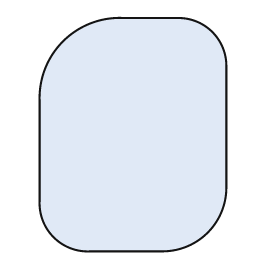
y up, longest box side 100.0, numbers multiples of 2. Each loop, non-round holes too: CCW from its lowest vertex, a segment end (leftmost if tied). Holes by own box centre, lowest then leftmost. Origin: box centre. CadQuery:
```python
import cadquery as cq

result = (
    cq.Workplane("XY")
    .moveTo(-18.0, -50.0)
    .lineTo(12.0, -50.0)
    .threePointArc((32.0, -42.0), (40.0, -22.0))
    .lineTo(40.0, 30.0)
    .threePointArc((34.0, 44.0), (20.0, 50.0))
    .lineTo(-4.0, 50.0)
    .threePointArc((-30.0, 40.0), (-40.0, 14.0))
    .lineTo(-40.0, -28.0)
    .threePointArc((-34.0, -44.0), (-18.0, -50.0))
    .close()
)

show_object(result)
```